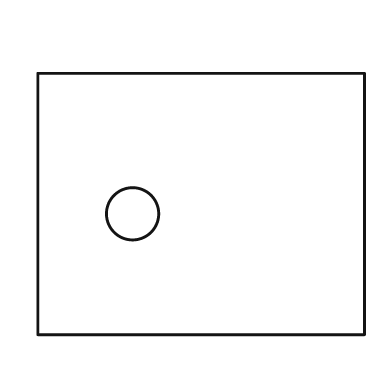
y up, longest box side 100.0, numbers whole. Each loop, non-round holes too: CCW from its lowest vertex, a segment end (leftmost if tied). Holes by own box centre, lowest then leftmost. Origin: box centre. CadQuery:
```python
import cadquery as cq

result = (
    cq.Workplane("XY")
    .moveTo(-50.0, -40.0)
    .lineTo(50.0, -40.0)
    .lineTo(50.0, 40.0)
    .lineTo(-50.0, 40.0)
    .close()
    .moveTo(-21.0, -3.0)
    .circle(8.0)
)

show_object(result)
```